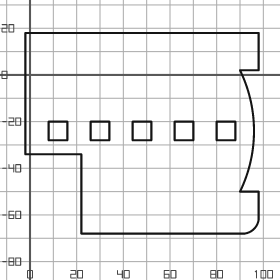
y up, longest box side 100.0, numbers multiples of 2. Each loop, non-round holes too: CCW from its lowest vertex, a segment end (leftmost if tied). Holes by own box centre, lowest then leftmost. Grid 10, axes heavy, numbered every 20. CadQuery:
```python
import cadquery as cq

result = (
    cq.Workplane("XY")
    .moveTo(22.0, -68.0)
    .lineTo(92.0, -68.0)
    .threePointArc((96.0, -66.0), (98.0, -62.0))
    .lineTo(98.0, -50.0)
    .lineTo(90.0, -50.0)
    .threePointArc((96.0, -24.0), (90.0, 2.0))
    .lineTo(98.0, 2.0)
    .lineTo(98.0, 18.0)
    .lineTo(-2.0, 18.0)
    .lineTo(-2.0, -34.0)
    .lineTo(22.0, -34.0)
    .close()
    .moveTo(8.0, -28.0)
    .lineTo(16.0, -28.0)
    .lineTo(16.0, -20.0)
    .lineTo(8.0, -20.0)
    .close()
    .moveTo(26.0, -28.0)
    .lineTo(34.0, -28.0)
    .lineTo(34.0, -20.0)
    .lineTo(26.0, -20.0)
    .close()
    .moveTo(44.0, -28.0)
    .lineTo(52.0, -28.0)
    .lineTo(52.0, -20.0)
    .lineTo(44.0, -20.0)
    .close()
    .moveTo(62.0, -28.0)
    .lineTo(70.0, -28.0)
    .lineTo(70.0, -20.0)
    .lineTo(62.0, -20.0)
    .close()
    .moveTo(80.0, -28.0)
    .lineTo(88.0, -28.0)
    .lineTo(88.0, -20.0)
    .lineTo(80.0, -20.0)
    .close()
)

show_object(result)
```